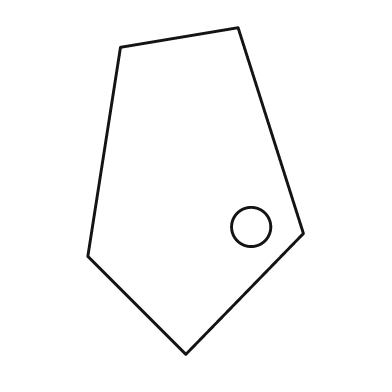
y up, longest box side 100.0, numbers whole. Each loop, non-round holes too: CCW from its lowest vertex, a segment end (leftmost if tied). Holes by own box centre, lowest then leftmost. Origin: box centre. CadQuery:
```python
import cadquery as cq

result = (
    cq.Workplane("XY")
    .moveTo(-3.0, -50.0)
    .lineTo(33.0, -13.0)
    .lineTo(13.0, 50.0)
    .lineTo(-23.0, 44.0)
    .lineTo(-33.0, -20.0)
    .close()
    .moveTo(17.0, -11.0)
    .circle(6.0)
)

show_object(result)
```